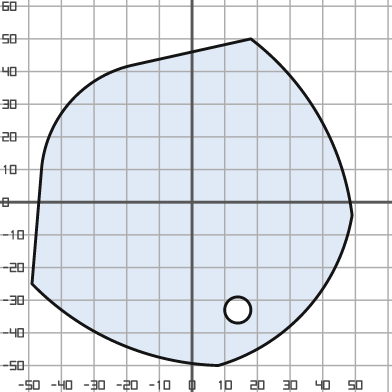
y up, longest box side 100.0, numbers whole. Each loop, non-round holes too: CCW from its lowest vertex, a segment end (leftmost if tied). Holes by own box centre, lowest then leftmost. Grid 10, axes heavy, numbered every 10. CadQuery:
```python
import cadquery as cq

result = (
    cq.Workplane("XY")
    .moveTo(8.0, -50.0)
    .threePointArc((35.0, -33.0), (49.0, -4.0))
    .threePointArc((39.0, 26.0), (18.0, 50.0))
    .lineTo(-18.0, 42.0)
    .threePointArc((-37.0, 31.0), (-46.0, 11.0))
    .lineTo(-49.0, -25.0)
    .threePointArc((-23.0, -43.0), (8.0, -50.0))
    .close()
    .moveTo(14.0, -33.0)
    .circle(4.0)
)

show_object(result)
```